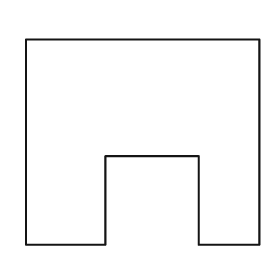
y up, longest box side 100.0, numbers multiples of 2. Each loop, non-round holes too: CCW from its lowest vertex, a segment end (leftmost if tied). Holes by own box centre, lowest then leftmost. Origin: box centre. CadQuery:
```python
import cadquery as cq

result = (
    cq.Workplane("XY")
    .moveTo(-50.0, -44.0)
    .lineTo(-16.0, -44.0)
    .lineTo(-16.0, -6.0)
    .lineTo(24.0, -6.0)
    .lineTo(24.0, -44.0)
    .lineTo(50.0, -44.0)
    .lineTo(50.0, 44.0)
    .lineTo(-50.0, 44.0)
    .close()
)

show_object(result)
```